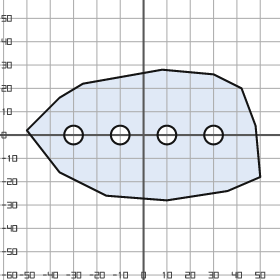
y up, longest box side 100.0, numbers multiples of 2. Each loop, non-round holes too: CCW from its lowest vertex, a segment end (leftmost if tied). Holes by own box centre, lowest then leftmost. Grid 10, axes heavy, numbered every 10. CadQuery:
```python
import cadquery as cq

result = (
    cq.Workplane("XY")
    .moveTo(10.0, -28.0)
    .lineTo(36.0, -24.0)
    .lineTo(50.0, -18.0)
    .lineTo(48.0, 4.0)
    .lineTo(42.0, 20.0)
    .lineTo(30.0, 26.0)
    .lineTo(8.0, 28.0)
    .lineTo(-26.0, 22.0)
    .lineTo(-36.0, 16.0)
    .lineTo(-50.0, 2.0)
    .lineTo(-36.0, -16.0)
    .lineTo(-16.0, -26.0)
    .close()
    .moveTo(-30.0, 0.0)
    .circle(4.0)
    .moveTo(-10.0, 0.0)
    .circle(4.0)
    .moveTo(10.0, 0.0)
    .circle(4.0)
    .moveTo(30.0, 0.0)
    .circle(4.0)
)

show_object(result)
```